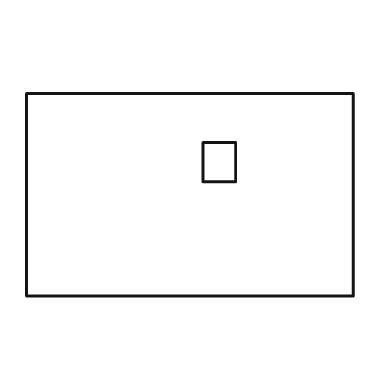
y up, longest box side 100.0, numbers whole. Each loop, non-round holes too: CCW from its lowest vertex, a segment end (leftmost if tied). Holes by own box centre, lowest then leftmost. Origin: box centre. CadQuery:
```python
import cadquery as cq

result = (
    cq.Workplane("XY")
    .moveTo(-50.0, -31.0)
    .lineTo(50.0, -31.0)
    .lineTo(50.0, 31.0)
    .lineTo(-50.0, 31.0)
    .close()
    .moveTo(4.0, 4.0)
    .lineTo(14.0, 4.0)
    .lineTo(14.0, 16.0)
    .lineTo(4.0, 16.0)
    .close()
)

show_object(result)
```